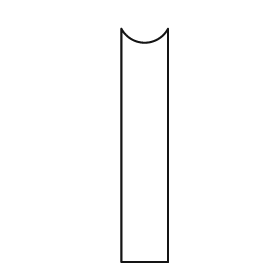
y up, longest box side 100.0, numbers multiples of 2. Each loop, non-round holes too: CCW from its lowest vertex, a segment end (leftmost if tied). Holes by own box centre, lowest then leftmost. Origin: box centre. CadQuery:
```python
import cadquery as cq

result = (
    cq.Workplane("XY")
    .moveTo(-10.0, -50.0)
    .lineTo(10.0, -50.0)
    .lineTo(10.0, 50.0)
    .threePointArc((0.0, 44.0), (-10.0, 50.0))
    .close()
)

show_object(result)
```